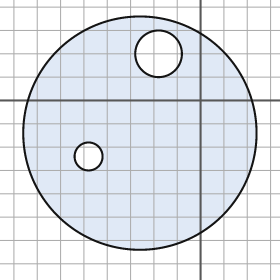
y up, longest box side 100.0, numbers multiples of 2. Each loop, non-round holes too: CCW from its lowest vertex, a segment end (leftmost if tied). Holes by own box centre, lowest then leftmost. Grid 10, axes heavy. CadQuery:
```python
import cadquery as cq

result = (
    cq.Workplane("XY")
    .moveTo(-26.0, -14.0)
    .circle(50.0)
    .moveTo(-48.0, -24.0)
    .circle(6.0)
    .moveTo(-18.0, 20.0)
    .circle(10.0)
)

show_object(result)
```